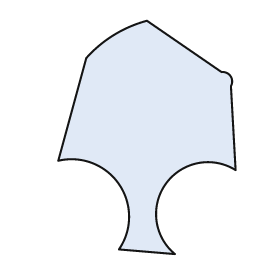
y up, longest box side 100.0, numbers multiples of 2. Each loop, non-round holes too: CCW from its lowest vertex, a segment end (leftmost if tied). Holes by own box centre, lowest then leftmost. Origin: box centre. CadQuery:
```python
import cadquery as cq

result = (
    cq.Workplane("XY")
    .moveTo(12.0, -50.0)
    .threePointArc((8.0, -20.0), (38.0, -14.0))
    .lineTo(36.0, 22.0)
    .threePointArc((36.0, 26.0), (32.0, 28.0))
    .lineTo(0.0, 50.0)
    .threePointArc((-14.0, 44.0), (-26.0, 34.0))
    .lineTo(-38.0, -10.0)
    .threePointArc((-12.0, -20.0), (-12.0, -48.0))
    .close()
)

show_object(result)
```